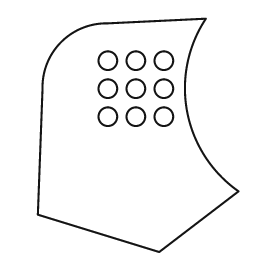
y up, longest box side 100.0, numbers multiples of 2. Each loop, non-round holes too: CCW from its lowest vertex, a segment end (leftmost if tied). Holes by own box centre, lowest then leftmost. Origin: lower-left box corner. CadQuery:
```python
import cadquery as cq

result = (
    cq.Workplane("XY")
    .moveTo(52.0, 0.0)
    .lineTo(86.0, 26.0)
    .threePointArc((64.0, 60.0), (72.0, 100.0))
    .lineTo(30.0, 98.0)
    .threePointArc((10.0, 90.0), (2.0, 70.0))
    .lineTo(0.0, 16.0)
    .close()
    .moveTo(30.0, 58.0)
    .circle(4.0)
    .moveTo(42.0, 58.0)
    .circle(4.0)
    .moveTo(54.0, 58.0)
    .circle(4.0)
    .moveTo(30.0, 70.0)
    .circle(4.0)
    .moveTo(42.0, 70.0)
    .circle(4.0)
    .moveTo(54.0, 70.0)
    .circle(4.0)
    .moveTo(30.0, 82.0)
    .circle(4.0)
    .moveTo(42.0, 82.0)
    .circle(4.0)
    .moveTo(54.0, 82.0)
    .circle(4.0)
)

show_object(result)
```